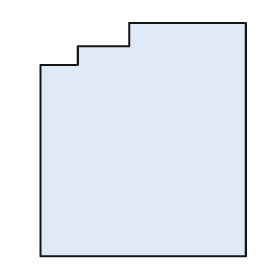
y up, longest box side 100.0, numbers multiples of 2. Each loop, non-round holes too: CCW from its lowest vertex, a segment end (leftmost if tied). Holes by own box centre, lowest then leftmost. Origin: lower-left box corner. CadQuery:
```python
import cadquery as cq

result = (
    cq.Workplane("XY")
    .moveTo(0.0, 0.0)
    .lineTo(88.0, 0.0)
    .lineTo(88.0, 100.0)
    .lineTo(38.0, 100.0)
    .lineTo(38.0, 90.0)
    .lineTo(16.0, 90.0)
    .lineTo(16.0, 82.0)
    .lineTo(0.0, 82.0)
    .close()
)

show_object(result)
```